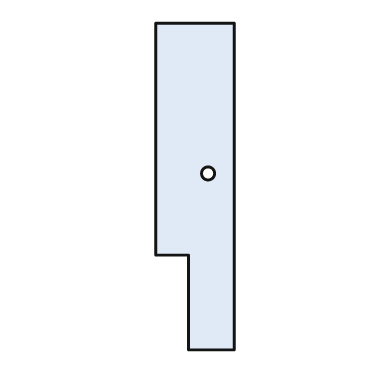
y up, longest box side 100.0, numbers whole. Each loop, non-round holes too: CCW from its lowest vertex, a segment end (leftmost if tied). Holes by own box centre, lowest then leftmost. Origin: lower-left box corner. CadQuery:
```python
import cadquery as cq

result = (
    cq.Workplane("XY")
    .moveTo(10.0, 0.0)
    .lineTo(24.0, 0.0)
    .lineTo(24.0, 100.0)
    .lineTo(0.0, 100.0)
    .lineTo(0.0, 29.0)
    .lineTo(10.0, 29.0)
    .close()
    .moveTo(16.0, 54.0)
    .circle(2.0)
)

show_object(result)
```